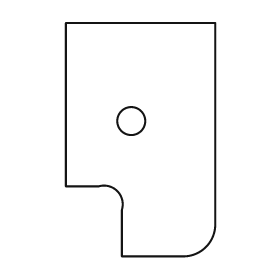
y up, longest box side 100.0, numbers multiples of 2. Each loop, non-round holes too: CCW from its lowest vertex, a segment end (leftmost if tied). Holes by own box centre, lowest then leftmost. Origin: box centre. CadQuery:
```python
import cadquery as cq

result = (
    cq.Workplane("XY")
    .moveTo(-8.0, -50.0)
    .lineTo(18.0, -50.0)
    .threePointArc((28.0, -46.0), (32.0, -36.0))
    .lineTo(32.0, 50.0)
    .lineTo(-32.0, 50.0)
    .lineTo(-32.0, -20.0)
    .lineTo(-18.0, -20.0)
    .threePointArc((-10.0, -22.0), (-8.0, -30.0))
    .close()
    .moveTo(-4.0, 8.0)
    .circle(6.0)
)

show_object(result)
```